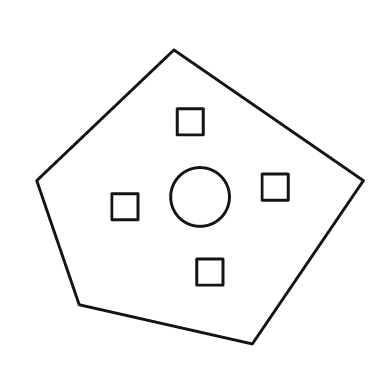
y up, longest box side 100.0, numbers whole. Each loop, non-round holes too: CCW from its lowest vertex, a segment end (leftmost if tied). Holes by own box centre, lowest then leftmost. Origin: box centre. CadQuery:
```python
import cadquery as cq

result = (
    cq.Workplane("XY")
    .moveTo(16.0, -45.0)
    .lineTo(50.0, 5.0)
    .lineTo(-8.0, 45.0)
    .lineTo(-50.0, 5.0)
    .lineTo(-37.0, -33.0)
    .close()
    .moveTo(-1.0, -27.0)
    .lineTo(7.0, -27.0)
    .lineTo(7.0, -19.0)
    .lineTo(-1.0, -19.0)
    .close()
    .moveTo(-27.0, -7.0)
    .lineTo(-19.0, -7.0)
    .lineTo(-19.0, 1.0)
    .lineTo(-27.0, 1.0)
    .close()
    .moveTo(0.0, 0.0)
    .circle(9.0)
    .moveTo(19.0, -1.0)
    .lineTo(27.0, -1.0)
    .lineTo(27.0, 7.0)
    .lineTo(19.0, 7.0)
    .close()
    .moveTo(-7.0, 19.0)
    .lineTo(1.0, 19.0)
    .lineTo(1.0, 27.0)
    .lineTo(-7.0, 27.0)
    .close()
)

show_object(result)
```